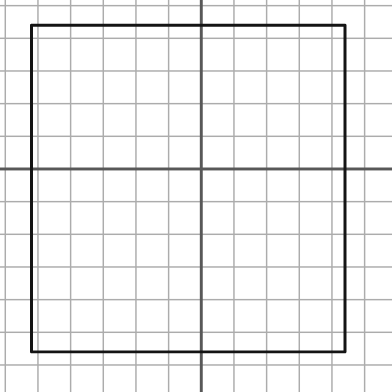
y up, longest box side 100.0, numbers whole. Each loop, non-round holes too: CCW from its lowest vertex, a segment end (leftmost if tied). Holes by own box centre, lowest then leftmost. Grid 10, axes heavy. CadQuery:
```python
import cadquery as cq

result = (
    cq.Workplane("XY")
    .moveTo(-52.0, -56.0)
    .lineTo(44.0, -56.0)
    .lineTo(44.0, 44.0)
    .lineTo(-52.0, 44.0)
    .close()
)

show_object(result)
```